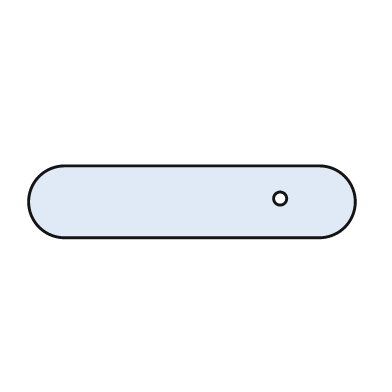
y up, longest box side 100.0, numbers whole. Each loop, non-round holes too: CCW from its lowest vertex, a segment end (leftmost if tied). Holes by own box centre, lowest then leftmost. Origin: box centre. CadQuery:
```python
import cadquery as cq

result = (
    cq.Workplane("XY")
    .moveTo(-39.0, -11.0)
    .lineTo(39.0, -11.0)
    .threePointArc((50.0, 0.0), (39.0, 11.0))
    .lineTo(-39.0, 11.0)
    .threePointArc((-50.0, 0.0), (-39.0, -11.0))
    .close()
    .moveTo(27.0, 1.0)
    .circle(2.0)
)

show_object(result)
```